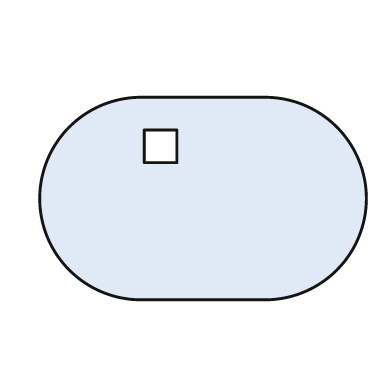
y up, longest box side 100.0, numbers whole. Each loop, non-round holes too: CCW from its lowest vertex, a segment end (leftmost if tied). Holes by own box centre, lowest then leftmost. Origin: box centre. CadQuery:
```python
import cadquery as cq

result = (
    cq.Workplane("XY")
    .moveTo(-19.0, -31.0)
    .lineTo(19.0, -31.0)
    .threePointArc((50.0, 0.0), (19.0, 31.0))
    .lineTo(-19.0, 31.0)
    .threePointArc((-50.0, 0.0), (-19.0, -31.0))
    .close()
    .moveTo(-18.0, 11.0)
    .lineTo(-8.0, 11.0)
    .lineTo(-8.0, 21.0)
    .lineTo(-18.0, 21.0)
    .close()
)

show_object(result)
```